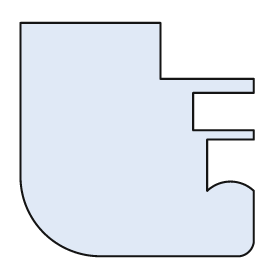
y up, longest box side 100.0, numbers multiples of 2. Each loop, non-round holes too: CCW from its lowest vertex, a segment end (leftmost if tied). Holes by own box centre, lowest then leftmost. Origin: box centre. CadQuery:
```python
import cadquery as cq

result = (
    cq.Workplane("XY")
    .moveTo(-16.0, -50.0)
    .lineTo(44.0, -50.0)
    .threePointArc((48.0, -48.0), (50.0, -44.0))
    .lineTo(50.0, -22.0)
    .threePointArc((40.0, -18.0), (30.0, -22.0))
    .lineTo(30.0, 0.0)
    .lineTo(50.0, 0.0)
    .lineTo(50.0, 4.0)
    .lineTo(24.0, 4.0)
    .lineTo(24.0, 20.0)
    .lineTo(50.0, 20.0)
    .lineTo(50.0, 26.0)
    .lineTo(10.0, 26.0)
    .lineTo(10.0, 50.0)
    .lineTo(-50.0, 50.0)
    .lineTo(-50.0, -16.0)
    .threePointArc((-40.0, -40.0), (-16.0, -50.0))
    .close()
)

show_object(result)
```